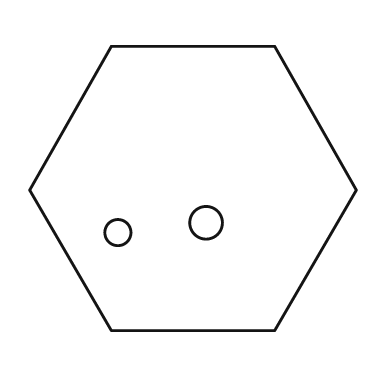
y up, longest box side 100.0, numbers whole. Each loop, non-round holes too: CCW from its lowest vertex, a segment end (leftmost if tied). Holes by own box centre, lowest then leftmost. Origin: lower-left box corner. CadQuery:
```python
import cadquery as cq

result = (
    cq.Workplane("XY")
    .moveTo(25.0, 0.0)
    .lineTo(75.0, 0.0)
    .lineTo(100.0, 43.0)
    .lineTo(75.0, 87.0)
    .lineTo(25.0, 87.0)
    .lineTo(0.0, 43.0)
    .close()
    .moveTo(27.0, 30.0)
    .circle(4.0)
    .moveTo(54.0, 33.0)
    .circle(5.0)
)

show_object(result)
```